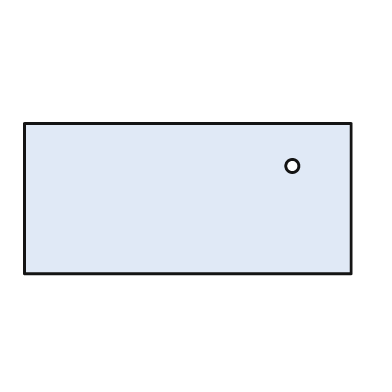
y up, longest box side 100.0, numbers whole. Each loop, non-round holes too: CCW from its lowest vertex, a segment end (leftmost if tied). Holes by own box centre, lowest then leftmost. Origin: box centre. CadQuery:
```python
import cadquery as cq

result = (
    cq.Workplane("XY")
    .moveTo(-50.0, -23.0)
    .lineTo(50.0, -23.0)
    .lineTo(50.0, 23.0)
    .lineTo(-50.0, 23.0)
    .close()
    .moveTo(32.0, 10.0)
    .circle(2.0)
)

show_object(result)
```